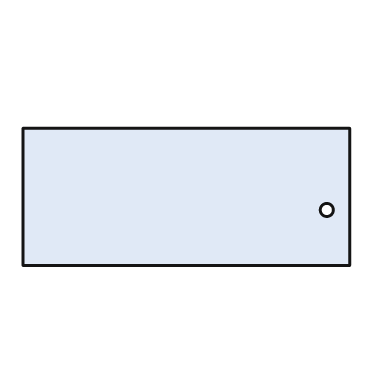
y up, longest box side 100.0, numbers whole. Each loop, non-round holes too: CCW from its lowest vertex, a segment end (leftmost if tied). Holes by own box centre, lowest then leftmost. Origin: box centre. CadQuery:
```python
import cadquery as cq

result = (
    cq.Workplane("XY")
    .moveTo(-50.0, -21.0)
    .lineTo(50.0, -21.0)
    .lineTo(50.0, 21.0)
    .lineTo(-50.0, 21.0)
    .close()
    .moveTo(43.0, -4.0)
    .circle(2.0)
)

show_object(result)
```